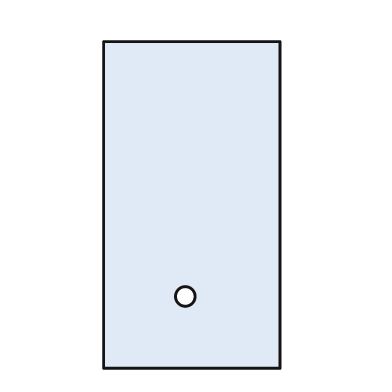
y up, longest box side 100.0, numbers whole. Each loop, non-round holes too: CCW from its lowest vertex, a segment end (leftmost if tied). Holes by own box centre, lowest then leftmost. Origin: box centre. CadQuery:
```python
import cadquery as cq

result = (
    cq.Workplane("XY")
    .moveTo(-27.0, -50.0)
    .lineTo(27.0, -50.0)
    .lineTo(27.0, 50.0)
    .lineTo(-27.0, 50.0)
    .close()
    .moveTo(-2.0, -28.0)
    .circle(3.0)
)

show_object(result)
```